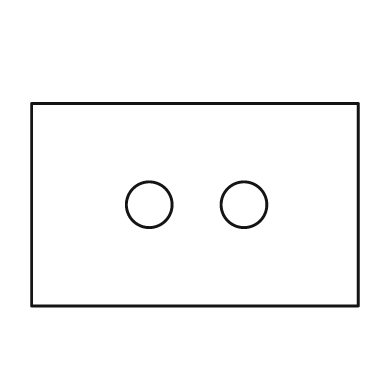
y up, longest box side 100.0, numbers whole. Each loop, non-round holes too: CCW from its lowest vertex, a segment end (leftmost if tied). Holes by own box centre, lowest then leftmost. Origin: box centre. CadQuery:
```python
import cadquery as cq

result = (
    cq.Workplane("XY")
    .moveTo(-50.0, -31.0)
    .lineTo(50.0, -31.0)
    .lineTo(50.0, 31.0)
    .lineTo(-50.0, 31.0)
    .close()
    .moveTo(-14.0, 0.0)
    .circle(7.0)
    .moveTo(15.0, 0.0)
    .circle(7.0)
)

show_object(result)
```